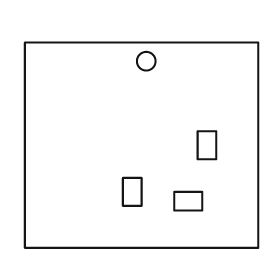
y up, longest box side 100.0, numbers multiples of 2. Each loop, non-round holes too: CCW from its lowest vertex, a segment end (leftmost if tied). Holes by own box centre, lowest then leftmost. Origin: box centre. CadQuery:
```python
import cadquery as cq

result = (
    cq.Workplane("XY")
    .moveTo(-50.0, -44.0)
    .lineTo(50.0, -44.0)
    .lineTo(50.0, 44.0)
    .lineTo(-50.0, 44.0)
    .close()
    .moveTo(14.0, -28.0)
    .lineTo(26.0, -28.0)
    .lineTo(26.0, -20.0)
    .lineTo(14.0, -20.0)
    .close()
    .moveTo(-8.0, -26.0)
    .lineTo(0.0, -26.0)
    .lineTo(0.0, -14.0)
    .lineTo(-8.0, -14.0)
    .close()
    .moveTo(24.0, -6.0)
    .lineTo(32.0, -6.0)
    .lineTo(32.0, 6.0)
    .lineTo(24.0, 6.0)
    .close()
    .moveTo(2.0, 36.0)
    .circle(4.0)
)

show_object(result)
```